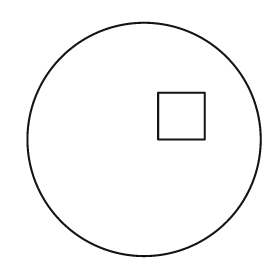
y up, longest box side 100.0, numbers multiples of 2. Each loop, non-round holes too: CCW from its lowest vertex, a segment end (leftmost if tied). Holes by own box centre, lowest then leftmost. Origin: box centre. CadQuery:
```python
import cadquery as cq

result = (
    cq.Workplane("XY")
    .moveTo(0.0, 0.0)
    .circle(50.0)
    .moveTo(6.0, 0.0)
    .lineTo(26.0, 0.0)
    .lineTo(26.0, 20.0)
    .lineTo(6.0, 20.0)
    .close()
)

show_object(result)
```